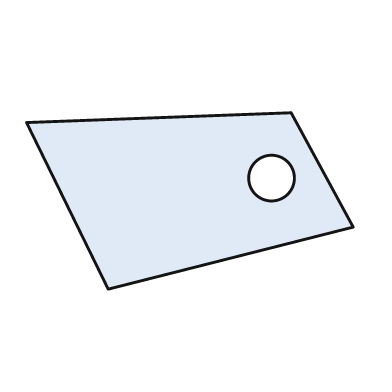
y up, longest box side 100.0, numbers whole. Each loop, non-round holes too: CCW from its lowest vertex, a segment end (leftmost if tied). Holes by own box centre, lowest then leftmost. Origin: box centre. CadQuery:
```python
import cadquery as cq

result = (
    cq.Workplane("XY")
    .moveTo(-25.0, -27.0)
    .lineTo(50.0, -8.0)
    .lineTo(31.0, 27.0)
    .lineTo(-50.0, 24.0)
    .close()
    .moveTo(25.0, 7.0)
    .circle(7.0)
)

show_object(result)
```